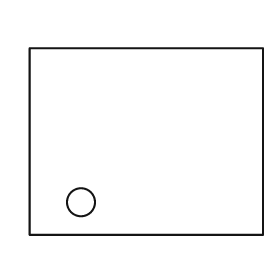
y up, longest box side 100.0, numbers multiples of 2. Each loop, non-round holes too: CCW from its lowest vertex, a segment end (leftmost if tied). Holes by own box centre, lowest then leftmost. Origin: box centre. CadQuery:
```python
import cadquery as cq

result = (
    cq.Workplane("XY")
    .moveTo(-50.0, -40.0)
    .lineTo(50.0, -40.0)
    .lineTo(50.0, 40.0)
    .lineTo(-50.0, 40.0)
    .close()
    .moveTo(-28.0, -26.0)
    .circle(6.0)
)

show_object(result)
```